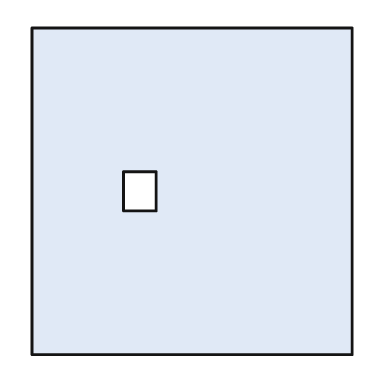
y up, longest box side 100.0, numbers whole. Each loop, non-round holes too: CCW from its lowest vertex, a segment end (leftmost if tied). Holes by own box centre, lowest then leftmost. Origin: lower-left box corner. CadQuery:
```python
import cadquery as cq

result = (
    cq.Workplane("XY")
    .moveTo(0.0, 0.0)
    .lineTo(98.0, 0.0)
    .lineTo(98.0, 100.0)
    .lineTo(0.0, 100.0)
    .close()
    .moveTo(28.0, 44.0)
    .lineTo(38.0, 44.0)
    .lineTo(38.0, 56.0)
    .lineTo(28.0, 56.0)
    .close()
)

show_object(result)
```